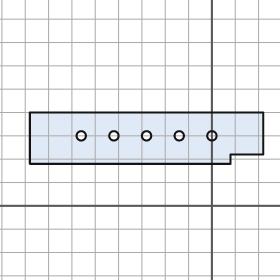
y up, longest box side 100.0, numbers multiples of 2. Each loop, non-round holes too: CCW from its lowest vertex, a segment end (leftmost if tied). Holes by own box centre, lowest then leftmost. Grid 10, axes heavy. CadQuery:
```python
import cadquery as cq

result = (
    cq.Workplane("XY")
    .moveTo(-78.0, 18.0)
    .lineTo(8.0, 18.0)
    .lineTo(8.0, 22.0)
    .lineTo(22.0, 22.0)
    .lineTo(22.0, 40.0)
    .lineTo(-78.0, 40.0)
    .close()
    .moveTo(-56.0, 30.0)
    .circle(2.0)
    .moveTo(-42.0, 30.0)
    .circle(2.0)
    .moveTo(-28.0, 30.0)
    .circle(2.0)
    .moveTo(-14.0, 30.0)
    .circle(2.0)
    .moveTo(0.0, 30.0)
    .circle(2.0)
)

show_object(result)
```